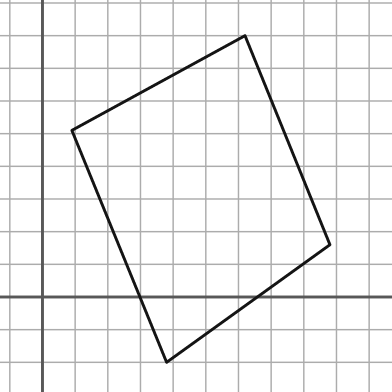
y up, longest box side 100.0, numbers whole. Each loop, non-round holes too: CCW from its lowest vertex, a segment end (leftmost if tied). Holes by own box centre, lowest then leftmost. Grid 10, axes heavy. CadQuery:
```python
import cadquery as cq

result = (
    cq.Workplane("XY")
    .moveTo(38.0, -20.0)
    .lineTo(88.0, 16.0)
    .lineTo(62.0, 80.0)
    .lineTo(9.0, 51.0)
    .close()
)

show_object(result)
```